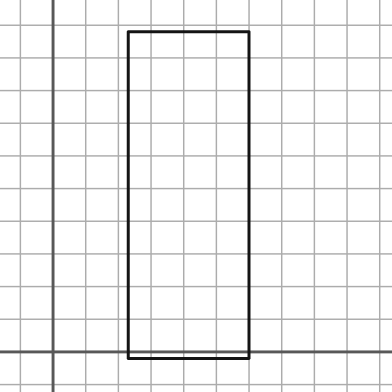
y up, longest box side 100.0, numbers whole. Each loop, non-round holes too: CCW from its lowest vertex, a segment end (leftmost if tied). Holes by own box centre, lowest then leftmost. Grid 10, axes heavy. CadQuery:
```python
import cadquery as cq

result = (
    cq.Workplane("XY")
    .moveTo(23.0, -2.0)
    .lineTo(60.0, -2.0)
    .lineTo(60.0, 98.0)
    .lineTo(23.0, 98.0)
    .close()
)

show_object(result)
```